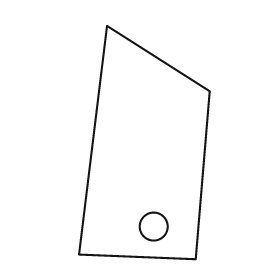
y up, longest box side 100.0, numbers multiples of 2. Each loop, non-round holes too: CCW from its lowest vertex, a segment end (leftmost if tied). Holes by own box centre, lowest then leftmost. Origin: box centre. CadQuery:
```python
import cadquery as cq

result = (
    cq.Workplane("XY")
    .moveTo(22.0, -50.0)
    .lineTo(28.0, 22.0)
    .lineTo(-16.0, 50.0)
    .lineTo(-28.0, -48.0)
    .close()
    .moveTo(4.0, -36.0)
    .circle(6.0)
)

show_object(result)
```